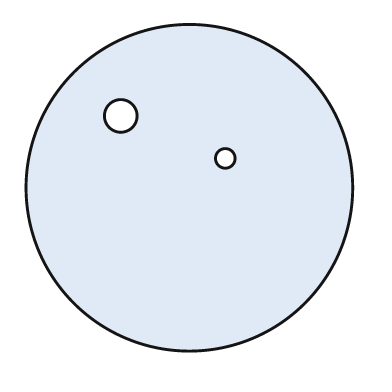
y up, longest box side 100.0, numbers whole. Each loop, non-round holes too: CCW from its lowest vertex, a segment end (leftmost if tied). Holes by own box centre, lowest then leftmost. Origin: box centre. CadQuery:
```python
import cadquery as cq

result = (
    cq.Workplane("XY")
    .moveTo(0.0, 0.0)
    .circle(50.0)
    .moveTo(11.0, 9.0)
    .circle(3.0)
    .moveTo(-21.0, 22.0)
    .circle(5.0)
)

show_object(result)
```